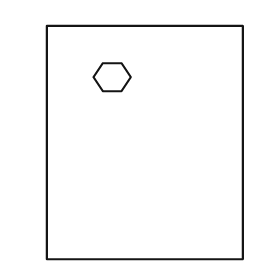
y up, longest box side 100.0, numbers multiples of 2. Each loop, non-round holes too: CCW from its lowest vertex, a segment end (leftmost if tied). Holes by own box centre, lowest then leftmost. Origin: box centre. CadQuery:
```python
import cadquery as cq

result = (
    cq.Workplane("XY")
    .moveTo(-42.0, -50.0)
    .lineTo(42.0, -50.0)
    .lineTo(42.0, 50.0)
    .lineTo(-42.0, 50.0)
    .close()
    .moveTo(-18.0, 22.0)
    .lineTo(-10.0, 22.0)
    .lineTo(-6.0, 28.0)
    .lineTo(-10.0, 34.0)
    .lineTo(-18.0, 34.0)
    .lineTo(-22.0, 28.0)
    .close()
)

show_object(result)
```